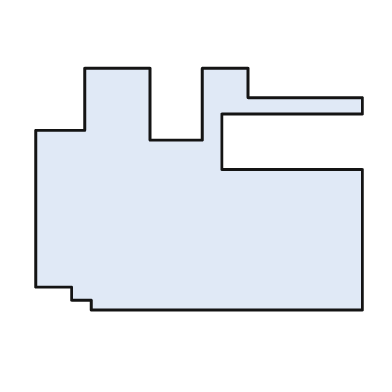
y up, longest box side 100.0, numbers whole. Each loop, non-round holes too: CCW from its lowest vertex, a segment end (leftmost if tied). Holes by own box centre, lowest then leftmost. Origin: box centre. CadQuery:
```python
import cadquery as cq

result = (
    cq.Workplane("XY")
    .moveTo(-33.0, -37.0)
    .lineTo(50.0, -37.0)
    .lineTo(50.0, 6.0)
    .lineTo(7.0, 6.0)
    .lineTo(7.0, 23.0)
    .lineTo(50.0, 23.0)
    .lineTo(50.0, 28.0)
    .lineTo(15.0, 28.0)
    .lineTo(15.0, 37.0)
    .lineTo(1.0, 37.0)
    .lineTo(1.0, 15.0)
    .lineTo(-15.0, 15.0)
    .lineTo(-15.0, 37.0)
    .lineTo(-35.0, 37.0)
    .lineTo(-35.0, 18.0)
    .lineTo(-50.0, 18.0)
    .lineTo(-50.0, -30.0)
    .lineTo(-39.0, -30.0)
    .lineTo(-39.0, -34.0)
    .lineTo(-33.0, -34.0)
    .close()
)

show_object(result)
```